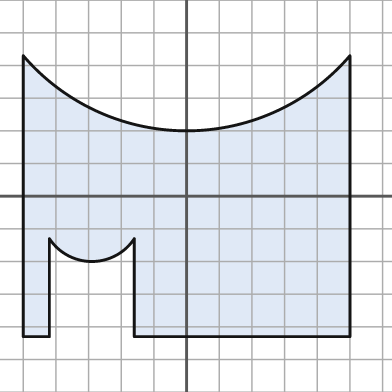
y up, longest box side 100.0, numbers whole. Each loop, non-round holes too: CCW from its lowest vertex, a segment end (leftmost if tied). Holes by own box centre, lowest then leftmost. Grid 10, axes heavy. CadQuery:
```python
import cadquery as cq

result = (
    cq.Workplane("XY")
    .moveTo(-50.0, -43.0)
    .lineTo(-42.0, -43.0)
    .lineTo(-42.0, -13.0)
    .threePointArc((-29.0, -20.0), (-16.0, -13.0))
    .lineTo(-16.0, -43.0)
    .lineTo(50.0, -43.0)
    .lineTo(50.0, 43.0)
    .threePointArc((0.0, 20.0), (-50.0, 43.0))
    .close()
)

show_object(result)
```